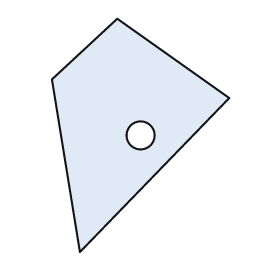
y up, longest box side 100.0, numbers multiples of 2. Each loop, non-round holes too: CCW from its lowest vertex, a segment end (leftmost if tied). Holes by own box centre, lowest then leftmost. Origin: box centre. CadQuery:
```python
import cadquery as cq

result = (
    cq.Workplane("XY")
    .moveTo(-26.0, -50.0)
    .lineTo(38.0, 16.0)
    .lineTo(-10.0, 50.0)
    .lineTo(-38.0, 24.0)
    .close()
    .moveTo(0.0, 0.0)
    .circle(6.0)
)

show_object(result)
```